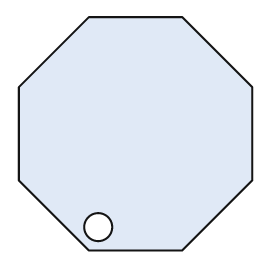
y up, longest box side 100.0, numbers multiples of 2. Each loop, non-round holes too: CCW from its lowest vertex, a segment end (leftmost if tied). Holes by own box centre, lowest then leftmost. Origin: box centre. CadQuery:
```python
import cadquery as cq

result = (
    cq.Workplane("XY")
    .moveTo(-20.0, -50.0)
    .lineTo(20.0, -50.0)
    .lineTo(50.0, -20.0)
    .lineTo(50.0, 20.0)
    .lineTo(20.0, 50.0)
    .lineTo(-20.0, 50.0)
    .lineTo(-50.0, 20.0)
    .lineTo(-50.0, -20.0)
    .close()
    .moveTo(-16.0, -40.0)
    .circle(6.0)
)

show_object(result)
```